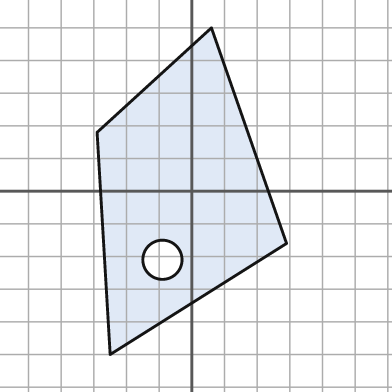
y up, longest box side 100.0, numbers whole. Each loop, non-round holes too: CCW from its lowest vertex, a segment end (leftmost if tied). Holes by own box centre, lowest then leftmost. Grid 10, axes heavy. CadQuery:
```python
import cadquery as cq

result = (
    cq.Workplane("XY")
    .moveTo(-25.0, -50.0)
    .lineTo(29.0, -16.0)
    .lineTo(6.0, 50.0)
    .lineTo(-29.0, 18.0)
    .close()
    .moveTo(-9.0, -21.0)
    .circle(6.0)
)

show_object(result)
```